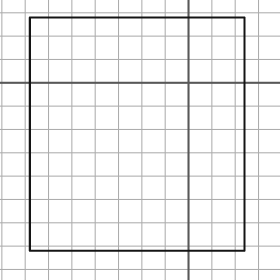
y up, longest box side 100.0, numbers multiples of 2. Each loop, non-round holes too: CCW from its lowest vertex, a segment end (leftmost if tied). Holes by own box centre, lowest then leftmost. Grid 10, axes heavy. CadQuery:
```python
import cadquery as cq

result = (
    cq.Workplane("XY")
    .moveTo(-68.0, -72.0)
    .lineTo(24.0, -72.0)
    .lineTo(24.0, 28.0)
    .lineTo(-68.0, 28.0)
    .close()
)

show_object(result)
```